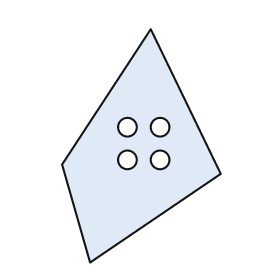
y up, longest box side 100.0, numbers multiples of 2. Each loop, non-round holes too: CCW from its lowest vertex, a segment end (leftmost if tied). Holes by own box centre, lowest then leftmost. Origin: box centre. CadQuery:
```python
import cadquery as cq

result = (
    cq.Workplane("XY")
    .moveTo(-22.0, -50.0)
    .lineTo(34.0, -12.0)
    .lineTo(4.0, 50.0)
    .lineTo(-34.0, -8.0)
    .close()
    .moveTo(-6.0, -6.0)
    .circle(4.0)
    .moveTo(8.0, -6.0)
    .circle(4.0)
    .moveTo(-6.0, 8.0)
    .circle(4.0)
    .moveTo(8.0, 8.0)
    .circle(4.0)
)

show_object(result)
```